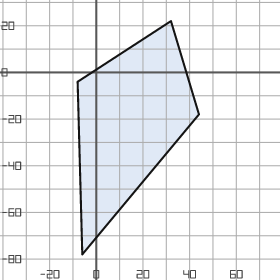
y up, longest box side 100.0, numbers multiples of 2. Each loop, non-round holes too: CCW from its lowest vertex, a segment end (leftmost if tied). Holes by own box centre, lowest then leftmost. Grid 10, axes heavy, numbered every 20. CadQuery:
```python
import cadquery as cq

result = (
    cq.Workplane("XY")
    .moveTo(-6.0, -78.0)
    .lineTo(44.0, -18.0)
    .lineTo(32.0, 22.0)
    .lineTo(-8.0, -4.0)
    .close()
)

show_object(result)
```